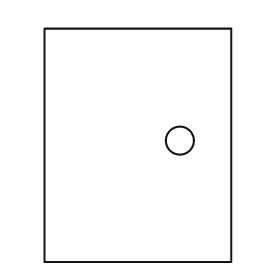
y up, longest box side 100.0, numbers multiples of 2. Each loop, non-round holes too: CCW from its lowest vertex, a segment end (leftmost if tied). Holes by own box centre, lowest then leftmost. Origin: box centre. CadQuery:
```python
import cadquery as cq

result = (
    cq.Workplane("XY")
    .moveTo(-40.0, -50.0)
    .lineTo(40.0, -50.0)
    .lineTo(40.0, 50.0)
    .lineTo(-40.0, 50.0)
    .close()
    .moveTo(18.0, 2.0)
    .circle(6.0)
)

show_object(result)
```